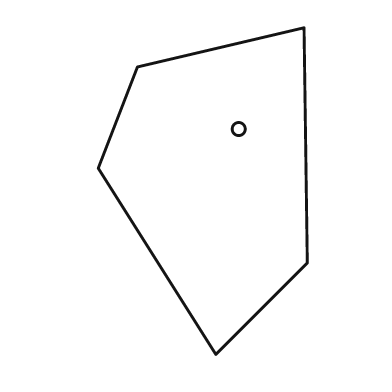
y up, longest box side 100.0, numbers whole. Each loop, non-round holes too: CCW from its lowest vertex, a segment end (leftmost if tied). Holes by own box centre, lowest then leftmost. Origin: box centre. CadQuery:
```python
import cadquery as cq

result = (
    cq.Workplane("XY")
    .moveTo(4.0, -50.0)
    .lineTo(32.0, -22.0)
    .lineTo(31.0, 50.0)
    .lineTo(-20.0, 38.0)
    .lineTo(-32.0, 7.0)
    .close()
    .moveTo(11.0, 19.0)
    .circle(2.0)
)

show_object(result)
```